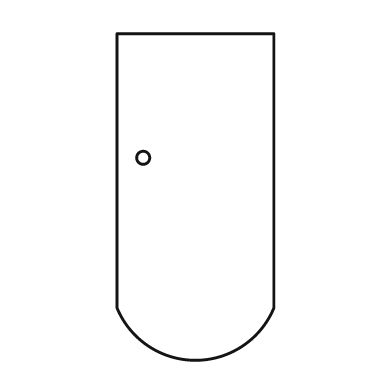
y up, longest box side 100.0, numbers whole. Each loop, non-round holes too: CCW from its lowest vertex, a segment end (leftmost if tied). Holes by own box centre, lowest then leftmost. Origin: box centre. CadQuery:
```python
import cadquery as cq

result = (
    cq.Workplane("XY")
    .moveTo(-24.0, -34.0)
    .threePointArc((0.0, -50.0), (24.0, -34.0))
    .lineTo(24.0, 50.0)
    .lineTo(-24.0, 50.0)
    .close()
    .moveTo(-16.0, 12.0)
    .circle(2.0)
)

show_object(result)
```